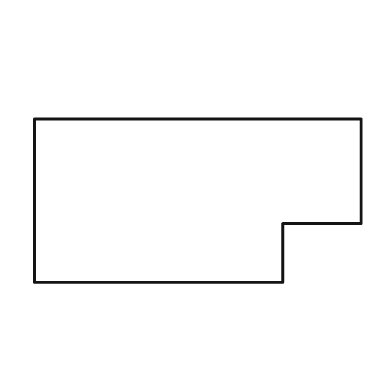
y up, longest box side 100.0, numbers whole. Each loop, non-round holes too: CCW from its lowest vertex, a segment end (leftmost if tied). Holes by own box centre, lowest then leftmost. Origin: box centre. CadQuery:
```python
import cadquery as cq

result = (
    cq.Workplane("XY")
    .moveTo(-50.0, -25.0)
    .lineTo(26.0, -25.0)
    .lineTo(26.0, -7.0)
    .lineTo(50.0, -7.0)
    .lineTo(50.0, 25.0)
    .lineTo(-50.0, 25.0)
    .close()
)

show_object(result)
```